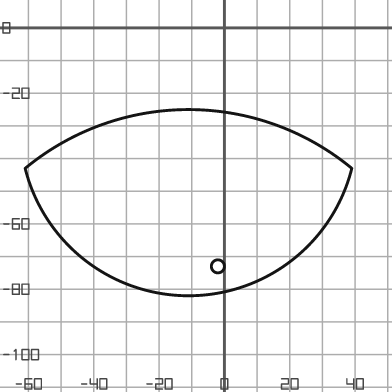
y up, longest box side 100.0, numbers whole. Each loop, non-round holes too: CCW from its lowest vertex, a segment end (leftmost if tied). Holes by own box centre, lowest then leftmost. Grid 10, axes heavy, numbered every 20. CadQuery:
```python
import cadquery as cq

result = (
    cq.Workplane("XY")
    .moveTo(-61.0, -43.0)
    .threePointArc((-11.0, -82.0), (39.0, -43.0))
    .threePointArc((-11.0, -25.0), (-61.0, -43.0))
    .close()
    .moveTo(-2.0, -73.0)
    .circle(2.0)
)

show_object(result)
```